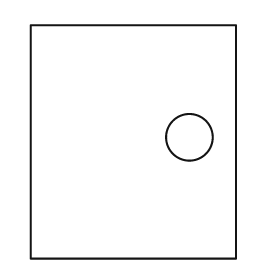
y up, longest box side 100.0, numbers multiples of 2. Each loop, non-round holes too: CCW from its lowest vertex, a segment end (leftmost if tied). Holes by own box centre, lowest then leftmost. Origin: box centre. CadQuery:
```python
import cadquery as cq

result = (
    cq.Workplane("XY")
    .moveTo(-44.0, -50.0)
    .lineTo(44.0, -50.0)
    .lineTo(44.0, 50.0)
    .lineTo(-44.0, 50.0)
    .close()
    .moveTo(24.0, 2.0)
    .circle(10.0)
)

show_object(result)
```